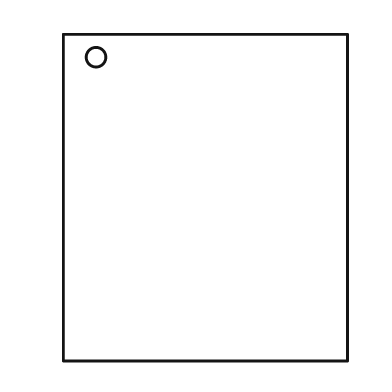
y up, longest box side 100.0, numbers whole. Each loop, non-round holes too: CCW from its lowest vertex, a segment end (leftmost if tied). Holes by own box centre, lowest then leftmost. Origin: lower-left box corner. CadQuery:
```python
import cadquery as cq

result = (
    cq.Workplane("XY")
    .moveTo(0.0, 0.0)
    .lineTo(87.0, 0.0)
    .lineTo(87.0, 100.0)
    .lineTo(0.0, 100.0)
    .close()
    .moveTo(10.0, 93.0)
    .circle(3.0)
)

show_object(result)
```